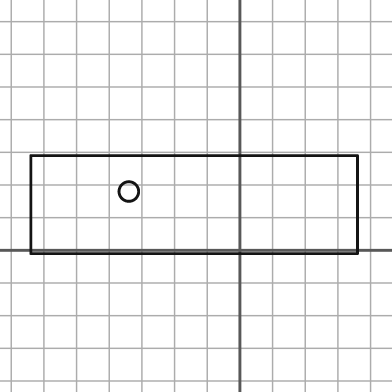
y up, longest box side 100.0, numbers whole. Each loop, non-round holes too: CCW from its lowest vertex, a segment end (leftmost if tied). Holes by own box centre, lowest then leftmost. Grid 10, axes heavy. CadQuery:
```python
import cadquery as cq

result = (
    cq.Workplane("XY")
    .moveTo(-64.0, -1.0)
    .lineTo(36.0, -1.0)
    .lineTo(36.0, 29.0)
    .lineTo(-64.0, 29.0)
    .close()
    .moveTo(-34.0, 18.0)
    .circle(3.0)
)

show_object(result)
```